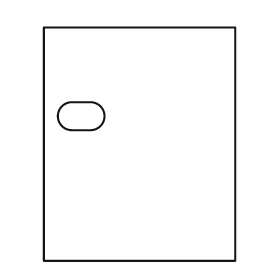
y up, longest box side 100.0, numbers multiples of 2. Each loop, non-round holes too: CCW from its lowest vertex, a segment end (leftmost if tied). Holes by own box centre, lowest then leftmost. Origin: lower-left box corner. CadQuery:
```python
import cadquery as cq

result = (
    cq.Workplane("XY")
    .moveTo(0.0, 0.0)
    .lineTo(82.0, 0.0)
    .lineTo(82.0, 100.0)
    .lineTo(0.0, 100.0)
    .close()
    .moveTo(12.0, 56.0)
    .lineTo(20.0, 56.0)
    .threePointArc((26.0, 62.0), (20.0, 68.0))
    .lineTo(12.0, 68.0)
    .threePointArc((6.0, 62.0), (12.0, 56.0))
    .close()
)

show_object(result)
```